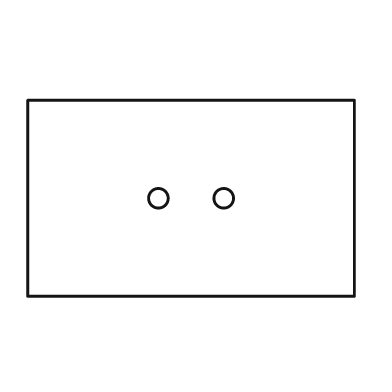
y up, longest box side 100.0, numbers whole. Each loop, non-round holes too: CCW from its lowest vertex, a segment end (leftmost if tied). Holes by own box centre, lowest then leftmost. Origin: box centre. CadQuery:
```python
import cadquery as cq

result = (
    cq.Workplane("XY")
    .moveTo(-50.0, -30.0)
    .lineTo(50.0, -30.0)
    .lineTo(50.0, 30.0)
    .lineTo(-50.0, 30.0)
    .close()
    .moveTo(-10.0, 0.0)
    .circle(3.0)
    .moveTo(10.0, 0.0)
    .circle(3.0)
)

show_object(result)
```